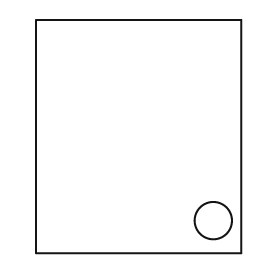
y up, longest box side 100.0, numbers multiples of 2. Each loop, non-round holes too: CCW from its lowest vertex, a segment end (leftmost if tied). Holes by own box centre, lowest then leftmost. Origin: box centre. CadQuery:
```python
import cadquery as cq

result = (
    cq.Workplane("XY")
    .moveTo(-44.0, -50.0)
    .lineTo(44.0, -50.0)
    .lineTo(44.0, 50.0)
    .lineTo(-44.0, 50.0)
    .close()
    .moveTo(32.0, -36.0)
    .circle(8.0)
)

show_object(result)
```